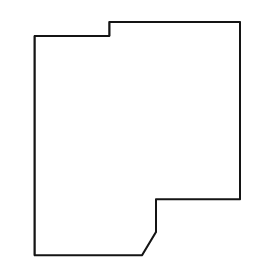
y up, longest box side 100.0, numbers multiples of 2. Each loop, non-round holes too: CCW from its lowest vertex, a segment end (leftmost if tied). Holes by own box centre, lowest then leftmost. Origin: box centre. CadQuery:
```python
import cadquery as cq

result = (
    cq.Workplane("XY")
    .moveTo(-44.0, -50.0)
    .lineTo(2.0, -50.0)
    .lineTo(8.0, -40.0)
    .lineTo(8.0, -26.0)
    .lineTo(44.0, -26.0)
    .lineTo(44.0, 50.0)
    .lineTo(-12.0, 50.0)
    .lineTo(-12.0, 44.0)
    .lineTo(-44.0, 44.0)
    .close()
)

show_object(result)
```